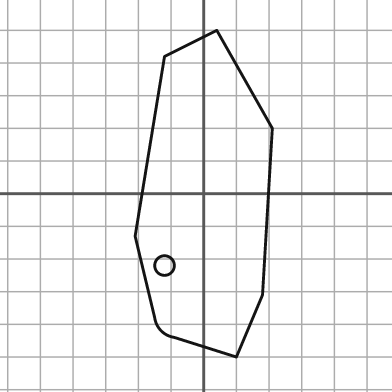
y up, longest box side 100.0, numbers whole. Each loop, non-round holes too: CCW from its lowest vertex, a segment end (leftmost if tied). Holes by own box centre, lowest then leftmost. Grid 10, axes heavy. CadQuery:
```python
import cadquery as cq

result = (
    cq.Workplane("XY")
    .moveTo(10.0, -50.0)
    .lineTo(18.0, -31.0)
    .lineTo(21.0, 20.0)
    .lineTo(4.0, 50.0)
    .lineTo(-12.0, 42.0)
    .lineTo(-21.0, -13.0)
    .lineTo(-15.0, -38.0)
    .threePointArc((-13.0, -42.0), (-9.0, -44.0))
    .close()
    .moveTo(-12.0, -22.0)
    .circle(3.0)
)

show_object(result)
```